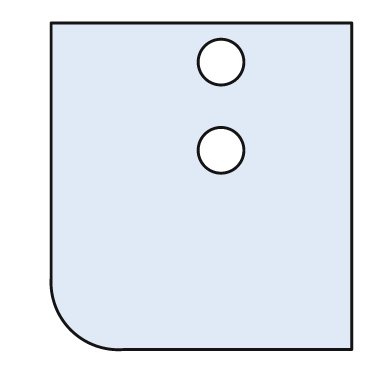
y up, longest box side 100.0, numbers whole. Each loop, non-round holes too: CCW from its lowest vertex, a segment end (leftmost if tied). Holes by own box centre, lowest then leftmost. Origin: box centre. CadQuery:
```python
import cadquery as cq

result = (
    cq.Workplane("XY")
    .moveTo(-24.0, -50.0)
    .lineTo(46.0, -50.0)
    .lineTo(46.0, 50.0)
    .lineTo(-46.0, 50.0)
    .lineTo(-46.0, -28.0)
    .threePointArc((-40.0, -44.0), (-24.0, -50.0))
    .close()
    .moveTo(6.0, 11.0)
    .circle(7.0)
    .moveTo(6.0, 38.0)
    .circle(7.0)
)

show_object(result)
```